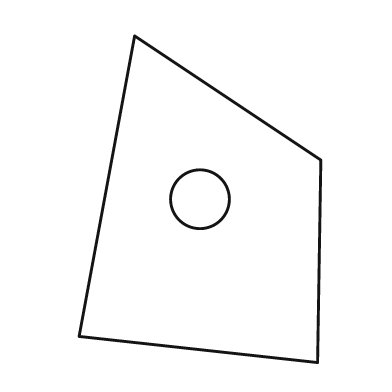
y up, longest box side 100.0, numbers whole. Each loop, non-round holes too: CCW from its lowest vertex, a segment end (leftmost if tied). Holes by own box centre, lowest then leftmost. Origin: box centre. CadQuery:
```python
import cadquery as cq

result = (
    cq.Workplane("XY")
    .moveTo(36.0, -50.0)
    .lineTo(37.0, 12.0)
    .lineTo(-20.0, 50.0)
    .lineTo(-37.0, -42.0)
    .close()
    .moveTo(0.0, 0.0)
    .circle(9.0)
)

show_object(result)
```